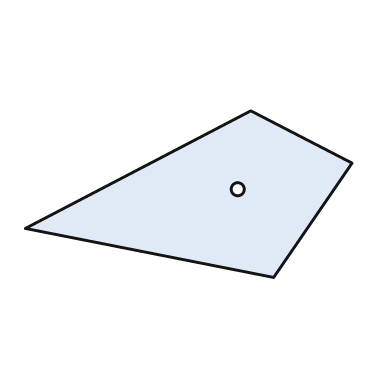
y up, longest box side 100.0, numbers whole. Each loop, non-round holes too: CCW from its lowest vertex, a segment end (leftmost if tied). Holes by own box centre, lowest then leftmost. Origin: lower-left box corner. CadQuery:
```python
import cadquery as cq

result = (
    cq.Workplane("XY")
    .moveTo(76.0, 0.0)
    .lineTo(100.0, 35.0)
    .lineTo(69.0, 51.0)
    .lineTo(0.0, 15.0)
    .close()
    .moveTo(65.0, 27.0)
    .circle(2.0)
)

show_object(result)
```